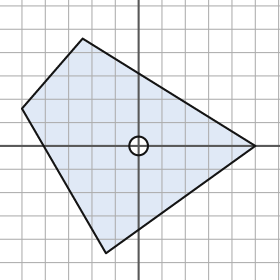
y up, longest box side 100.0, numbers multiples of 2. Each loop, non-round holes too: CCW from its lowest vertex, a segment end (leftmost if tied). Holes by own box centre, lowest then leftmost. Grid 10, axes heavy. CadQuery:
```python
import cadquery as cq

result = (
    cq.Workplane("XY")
    .moveTo(-14.0, -46.0)
    .lineTo(50.0, 0.0)
    .lineTo(-24.0, 46.0)
    .lineTo(-50.0, 16.0)
    .close()
    .moveTo(0.0, 0.0)
    .circle(4.0)
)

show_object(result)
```